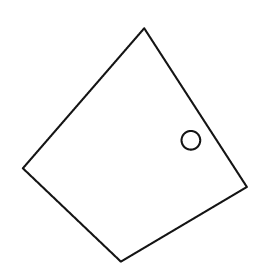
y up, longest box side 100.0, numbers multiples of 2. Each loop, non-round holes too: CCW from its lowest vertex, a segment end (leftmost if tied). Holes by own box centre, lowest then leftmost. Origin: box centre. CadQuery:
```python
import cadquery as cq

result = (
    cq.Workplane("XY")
    .moveTo(-6.0, -50.0)
    .lineTo(48.0, -18.0)
    .lineTo(4.0, 50.0)
    .lineTo(-48.0, -10.0)
    .close()
    .moveTo(24.0, 2.0)
    .circle(4.0)
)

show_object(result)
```